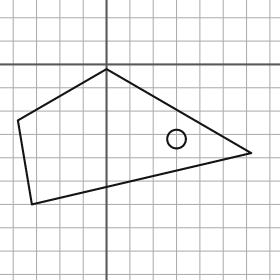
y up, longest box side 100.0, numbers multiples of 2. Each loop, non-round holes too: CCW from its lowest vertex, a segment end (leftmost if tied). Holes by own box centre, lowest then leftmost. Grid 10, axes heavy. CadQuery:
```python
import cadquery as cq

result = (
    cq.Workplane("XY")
    .moveTo(-32.0, -60.0)
    .lineTo(62.0, -38.0)
    .lineTo(0.0, -2.0)
    .lineTo(-38.0, -24.0)
    .close()
    .moveTo(30.0, -32.0)
    .circle(4.0)
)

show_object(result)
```